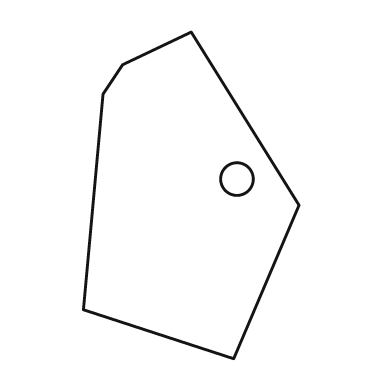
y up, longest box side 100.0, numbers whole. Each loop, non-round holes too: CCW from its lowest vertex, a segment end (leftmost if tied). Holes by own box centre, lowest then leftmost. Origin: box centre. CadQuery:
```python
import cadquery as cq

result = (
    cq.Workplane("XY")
    .moveTo(13.0, -50.0)
    .lineTo(33.0, -3.0)
    .lineTo(0.0, 50.0)
    .lineTo(-21.0, 40.0)
    .lineTo(-27.0, 31.0)
    .lineTo(-33.0, -35.0)
    .close()
    .moveTo(14.0, 5.0)
    .circle(5.0)
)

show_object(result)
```